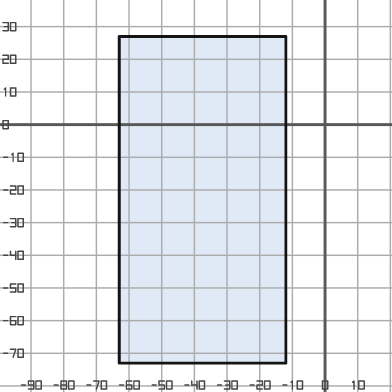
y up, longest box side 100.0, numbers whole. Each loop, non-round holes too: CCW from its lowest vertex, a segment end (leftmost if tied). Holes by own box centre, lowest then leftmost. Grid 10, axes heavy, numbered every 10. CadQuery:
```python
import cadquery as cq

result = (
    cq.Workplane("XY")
    .moveTo(-63.0, -73.0)
    .lineTo(-12.0, -73.0)
    .lineTo(-12.0, 27.0)
    .lineTo(-63.0, 27.0)
    .close()
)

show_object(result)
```